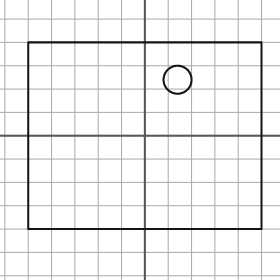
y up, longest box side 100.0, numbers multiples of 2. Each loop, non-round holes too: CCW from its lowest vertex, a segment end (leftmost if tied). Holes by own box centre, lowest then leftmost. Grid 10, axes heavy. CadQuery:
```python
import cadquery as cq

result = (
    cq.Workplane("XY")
    .moveTo(-50.0, -40.0)
    .lineTo(50.0, -40.0)
    .lineTo(50.0, 40.0)
    .lineTo(-50.0, 40.0)
    .close()
    .moveTo(14.0, 24.0)
    .circle(6.0)
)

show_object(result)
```